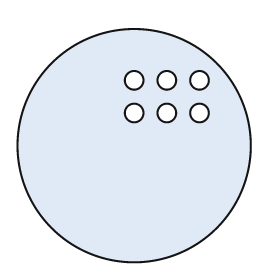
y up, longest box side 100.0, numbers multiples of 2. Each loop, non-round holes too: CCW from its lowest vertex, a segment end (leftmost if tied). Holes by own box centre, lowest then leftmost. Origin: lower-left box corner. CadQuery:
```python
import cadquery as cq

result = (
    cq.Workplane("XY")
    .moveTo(50.0, 50.0)
    .circle(50.0)
    .moveTo(50.0, 64.0)
    .circle(4.0)
    .moveTo(64.0, 64.0)
    .circle(4.0)
    .moveTo(78.0, 64.0)
    .circle(4.0)
    .moveTo(50.0, 78.0)
    .circle(4.0)
    .moveTo(64.0, 78.0)
    .circle(4.0)
    .moveTo(78.0, 78.0)
    .circle(4.0)
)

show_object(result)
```